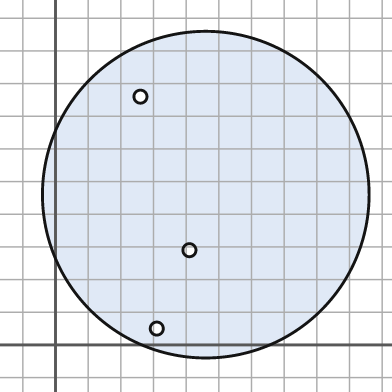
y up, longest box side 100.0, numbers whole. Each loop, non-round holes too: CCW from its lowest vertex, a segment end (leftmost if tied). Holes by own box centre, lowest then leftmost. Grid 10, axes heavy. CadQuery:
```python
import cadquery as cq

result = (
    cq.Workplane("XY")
    .moveTo(46.0, 46.0)
    .circle(50.0)
    .moveTo(31.0, 5.0)
    .circle(2.0)
    .moveTo(41.0, 29.0)
    .circle(2.0)
    .moveTo(26.0, 76.0)
    .circle(2.0)
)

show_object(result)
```